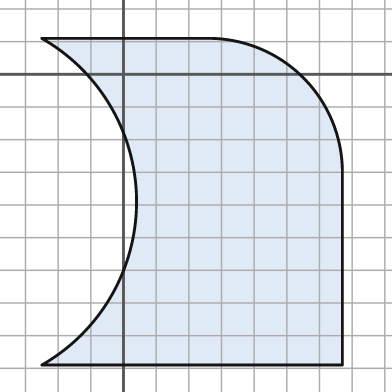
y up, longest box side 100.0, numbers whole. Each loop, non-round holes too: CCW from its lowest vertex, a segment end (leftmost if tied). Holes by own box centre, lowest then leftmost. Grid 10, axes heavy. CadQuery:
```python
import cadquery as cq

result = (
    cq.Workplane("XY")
    .moveTo(-25.0, -89.0)
    .lineTo(67.0, -89.0)
    .lineTo(67.0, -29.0)
    .threePointArc((55.0, -1.0), (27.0, 11.0))
    .lineTo(-25.0, 11.0)
    .threePointArc((4.0, -39.0), (-25.0, -89.0))
    .close()
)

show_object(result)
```